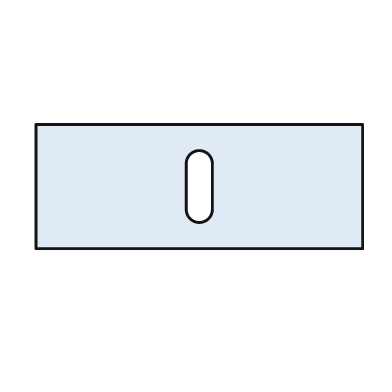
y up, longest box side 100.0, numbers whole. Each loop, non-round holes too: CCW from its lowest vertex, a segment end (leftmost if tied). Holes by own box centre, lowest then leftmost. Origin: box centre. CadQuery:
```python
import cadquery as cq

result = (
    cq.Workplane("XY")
    .moveTo(-50.0, -19.0)
    .lineTo(50.0, -19.0)
    .lineTo(50.0, 19.0)
    .lineTo(-50.0, 19.0)
    .close()
    .moveTo(-4.0, -7.0)
    .threePointArc((0.0, -11.0), (4.0, -7.0))
    .lineTo(4.0, 7.0)
    .threePointArc((0.0, 11.0), (-4.0, 7.0))
    .close()
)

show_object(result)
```